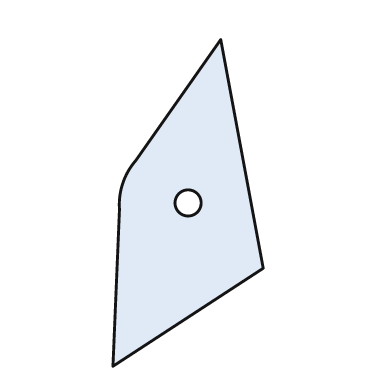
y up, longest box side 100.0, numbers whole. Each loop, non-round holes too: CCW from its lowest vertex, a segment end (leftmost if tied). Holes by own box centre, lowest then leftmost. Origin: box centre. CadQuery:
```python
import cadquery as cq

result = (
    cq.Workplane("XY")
    .moveTo(-23.0, -50.0)
    .lineTo(23.0, -20.0)
    .lineTo(10.0, 50.0)
    .lineTo(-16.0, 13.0)
    .threePointArc((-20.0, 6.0), (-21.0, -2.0))
    .close()
    .moveTo(0.0, 0.0)
    .circle(4.0)
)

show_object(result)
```